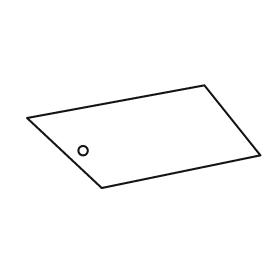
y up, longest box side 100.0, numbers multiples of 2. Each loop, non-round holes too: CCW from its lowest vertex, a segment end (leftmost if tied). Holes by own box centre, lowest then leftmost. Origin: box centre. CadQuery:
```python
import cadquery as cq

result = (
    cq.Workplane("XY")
    .moveTo(-18.0, -22.0)
    .lineTo(50.0, -8.0)
    .lineTo(26.0, 22.0)
    .lineTo(-50.0, 8.0)
    .close()
    .moveTo(-26.0, -6.0)
    .circle(2.0)
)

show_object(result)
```